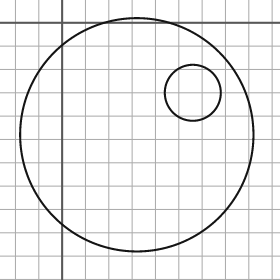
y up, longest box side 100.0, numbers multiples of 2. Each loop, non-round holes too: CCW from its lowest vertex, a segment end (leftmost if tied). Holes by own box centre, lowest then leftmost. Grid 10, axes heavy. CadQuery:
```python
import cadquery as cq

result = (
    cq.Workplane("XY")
    .moveTo(32.0, -48.0)
    .circle(50.0)
    .moveTo(56.0, -30.0)
    .circle(12.0)
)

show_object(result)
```